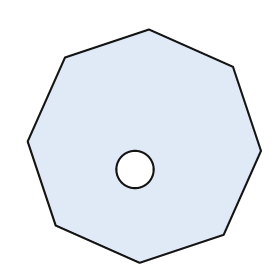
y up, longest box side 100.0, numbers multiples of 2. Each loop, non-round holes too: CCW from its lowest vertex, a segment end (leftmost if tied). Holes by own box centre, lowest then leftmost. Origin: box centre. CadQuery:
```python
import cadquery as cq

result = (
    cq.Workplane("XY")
    .moveTo(-2.0, -50.0)
    .lineTo(34.0, -38.0)
    .lineTo(50.0, -2.0)
    .lineTo(38.0, 34.0)
    .lineTo(2.0, 50.0)
    .lineTo(-34.0, 38.0)
    .lineTo(-50.0, 2.0)
    .lineTo(-38.0, -34.0)
    .close()
    .moveTo(-4.0, -10.0)
    .circle(8.0)
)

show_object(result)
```